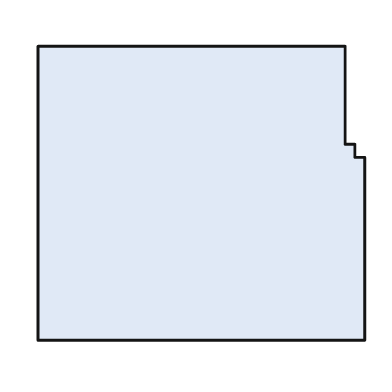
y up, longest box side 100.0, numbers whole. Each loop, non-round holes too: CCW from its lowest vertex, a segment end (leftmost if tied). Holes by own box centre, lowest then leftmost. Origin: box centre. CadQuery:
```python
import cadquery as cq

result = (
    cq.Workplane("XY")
    .moveTo(-50.0, -45.0)
    .lineTo(50.0, -45.0)
    .lineTo(50.0, 11.0)
    .lineTo(47.0, 11.0)
    .lineTo(47.0, 15.0)
    .lineTo(44.0, 15.0)
    .lineTo(44.0, 45.0)
    .lineTo(-50.0, 45.0)
    .close()
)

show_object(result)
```